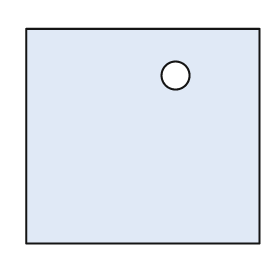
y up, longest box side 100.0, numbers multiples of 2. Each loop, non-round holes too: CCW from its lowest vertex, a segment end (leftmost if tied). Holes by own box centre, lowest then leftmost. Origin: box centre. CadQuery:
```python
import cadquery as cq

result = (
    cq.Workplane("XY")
    .moveTo(-50.0, -46.0)
    .lineTo(50.0, -46.0)
    .lineTo(50.0, 46.0)
    .lineTo(-50.0, 46.0)
    .close()
    .moveTo(14.0, 26.0)
    .circle(6.0)
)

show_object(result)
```